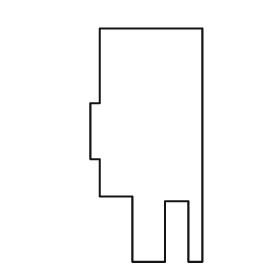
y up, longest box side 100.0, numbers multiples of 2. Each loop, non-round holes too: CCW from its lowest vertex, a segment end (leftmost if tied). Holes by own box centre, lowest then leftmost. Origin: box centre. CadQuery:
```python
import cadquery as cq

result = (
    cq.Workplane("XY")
    .moveTo(-6.0, -50.0)
    .lineTo(8.0, -50.0)
    .lineTo(8.0, -24.0)
    .lineTo(18.0, -24.0)
    .lineTo(18.0, -50.0)
    .lineTo(24.0, -50.0)
    .lineTo(24.0, 50.0)
    .lineTo(-20.0, 50.0)
    .lineTo(-20.0, 18.0)
    .lineTo(-24.0, 18.0)
    .lineTo(-24.0, -6.0)
    .lineTo(-20.0, -6.0)
    .lineTo(-20.0, -22.0)
    .lineTo(-6.0, -22.0)
    .close()
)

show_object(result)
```